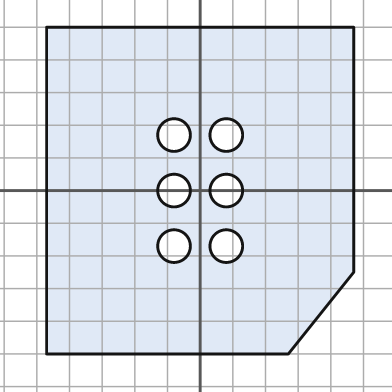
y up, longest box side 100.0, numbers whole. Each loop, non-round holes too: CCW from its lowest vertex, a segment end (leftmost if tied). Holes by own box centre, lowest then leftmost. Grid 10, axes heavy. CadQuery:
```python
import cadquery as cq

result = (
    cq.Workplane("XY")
    .moveTo(-47.0, -50.0)
    .lineTo(27.0, -50.0)
    .lineTo(47.0, -25.0)
    .lineTo(47.0, 50.0)
    .lineTo(-47.0, 50.0)
    .close()
    .moveTo(-8.0, -17.0)
    .circle(5.0)
    .moveTo(8.0, -17.0)
    .circle(5.0)
    .moveTo(-8.0, 0.0)
    .circle(5.0)
    .moveTo(8.0, 0.0)
    .circle(5.0)
    .moveTo(-8.0, 17.0)
    .circle(5.0)
    .moveTo(8.0, 17.0)
    .circle(5.0)
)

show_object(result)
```